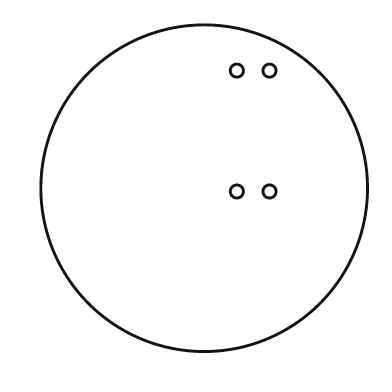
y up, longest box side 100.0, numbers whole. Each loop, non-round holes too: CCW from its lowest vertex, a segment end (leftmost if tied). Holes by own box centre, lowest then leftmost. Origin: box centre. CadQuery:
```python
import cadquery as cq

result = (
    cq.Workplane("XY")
    .moveTo(0.0, 0.0)
    .circle(50.0)
    .moveTo(10.0, -1.0)
    .circle(2.0)
    .moveTo(20.0, -1.0)
    .circle(2.0)
    .moveTo(10.0, 36.0)
    .circle(2.0)
    .moveTo(20.0, 36.0)
    .circle(2.0)
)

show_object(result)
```